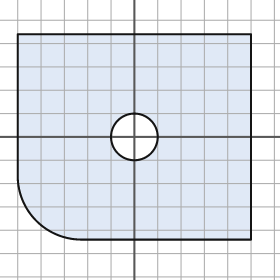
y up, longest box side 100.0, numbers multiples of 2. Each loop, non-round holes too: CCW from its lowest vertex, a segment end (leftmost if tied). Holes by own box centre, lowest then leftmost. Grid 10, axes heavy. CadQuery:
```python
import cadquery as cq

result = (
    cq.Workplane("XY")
    .moveTo(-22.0, -44.0)
    .lineTo(50.0, -44.0)
    .lineTo(50.0, 44.0)
    .lineTo(-50.0, 44.0)
    .lineTo(-50.0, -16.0)
    .threePointArc((-42.0, -36.0), (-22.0, -44.0))
    .close()
    .moveTo(0.0, 0.0)
    .circle(10.0)
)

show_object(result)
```